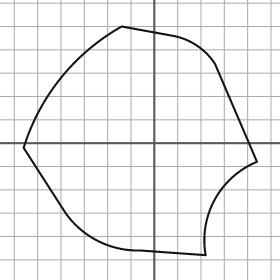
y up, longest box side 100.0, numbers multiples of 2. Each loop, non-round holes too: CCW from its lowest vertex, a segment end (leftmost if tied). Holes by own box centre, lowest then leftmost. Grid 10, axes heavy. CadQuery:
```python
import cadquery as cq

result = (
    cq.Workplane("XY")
    .moveTo(22.0, -48.0)
    .threePointArc((26.0, -24.0), (44.0, -8.0))
    .lineTo(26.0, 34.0)
    .threePointArc((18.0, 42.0), (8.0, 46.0))
    .lineTo(-14.0, 50.0)
    .threePointArc((-40.0, 28.0), (-56.0, -2.0))
    .lineTo(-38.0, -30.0)
    .threePointArc((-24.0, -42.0), (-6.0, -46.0))
    .close()
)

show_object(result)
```